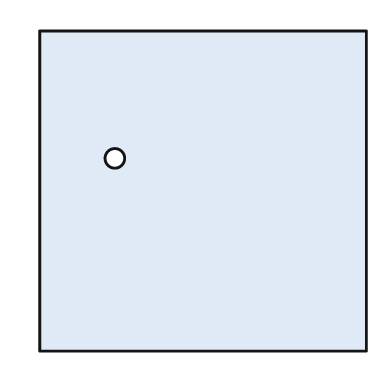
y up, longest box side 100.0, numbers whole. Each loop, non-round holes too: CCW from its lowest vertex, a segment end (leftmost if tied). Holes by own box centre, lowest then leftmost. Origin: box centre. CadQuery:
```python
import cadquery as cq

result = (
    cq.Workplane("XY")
    .moveTo(-50.0, -49.0)
    .lineTo(50.0, -49.0)
    .lineTo(50.0, 49.0)
    .lineTo(-50.0, 49.0)
    .close()
    .moveTo(-27.0, 10.0)
    .circle(3.0)
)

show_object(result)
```